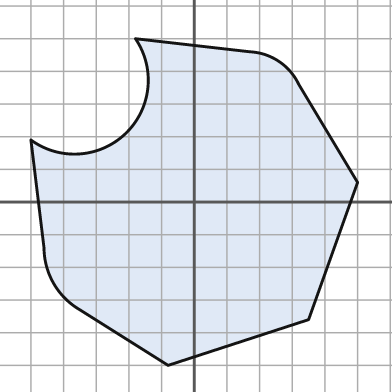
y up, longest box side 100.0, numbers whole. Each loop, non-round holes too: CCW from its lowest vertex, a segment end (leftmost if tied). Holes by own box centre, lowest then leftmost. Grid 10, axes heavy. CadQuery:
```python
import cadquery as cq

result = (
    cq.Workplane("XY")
    .moveTo(-8.0, -50.0)
    .lineTo(35.0, -36.0)
    .lineTo(50.0, 6.0)
    .lineTo(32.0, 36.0)
    .threePointArc((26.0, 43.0), (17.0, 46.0))
    .lineTo(-18.0, 50.0)
    .threePointArc((-21.0, 21.0), (-50.0, 19.0))
    .lineTo(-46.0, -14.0)
    .threePointArc((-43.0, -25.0), (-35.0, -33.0))
    .close()
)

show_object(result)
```